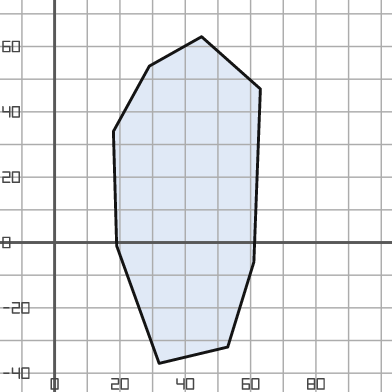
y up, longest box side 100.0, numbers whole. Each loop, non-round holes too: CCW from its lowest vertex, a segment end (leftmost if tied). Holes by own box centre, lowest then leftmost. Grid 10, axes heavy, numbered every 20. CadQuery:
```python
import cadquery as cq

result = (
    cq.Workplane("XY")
    .moveTo(32.0, -37.0)
    .lineTo(53.0, -32.0)
    .lineTo(61.0, -6.0)
    .lineTo(63.0, 47.0)
    .lineTo(45.0, 63.0)
    .lineTo(29.0, 54.0)
    .lineTo(18.0, 34.0)
    .lineTo(19.0, -1.0)
    .close()
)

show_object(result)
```